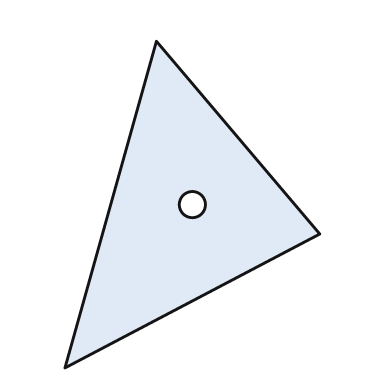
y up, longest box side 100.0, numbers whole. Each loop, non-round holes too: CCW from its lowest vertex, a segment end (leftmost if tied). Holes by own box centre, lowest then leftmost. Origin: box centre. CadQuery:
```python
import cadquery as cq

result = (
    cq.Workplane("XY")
    .moveTo(-39.0, -50.0)
    .lineTo(39.0, -9.0)
    .lineTo(-11.0, 50.0)
    .close()
    .moveTo(0.0, 0.0)
    .circle(4.0)
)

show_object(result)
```